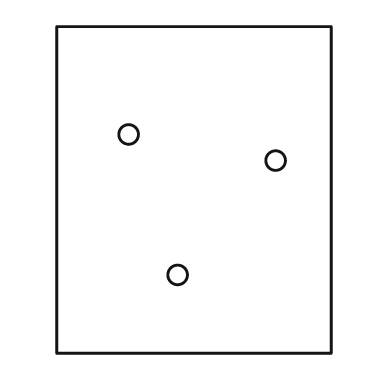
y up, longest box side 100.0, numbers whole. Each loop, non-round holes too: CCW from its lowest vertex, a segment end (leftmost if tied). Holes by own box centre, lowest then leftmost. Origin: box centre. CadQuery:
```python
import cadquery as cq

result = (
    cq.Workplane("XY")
    .moveTo(-42.0, -50.0)
    .lineTo(42.0, -50.0)
    .lineTo(42.0, 50.0)
    .lineTo(-42.0, 50.0)
    .close()
    .moveTo(-5.0, -26.0)
    .circle(3.0)
    .moveTo(25.0, 9.0)
    .circle(3.0)
    .moveTo(-20.0, 17.0)
    .circle(3.0)
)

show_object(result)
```